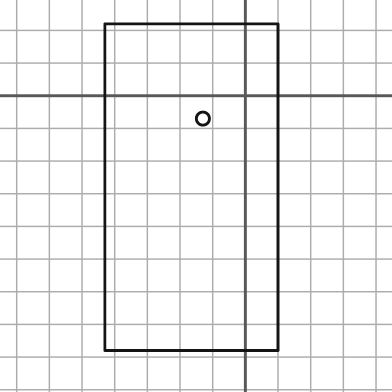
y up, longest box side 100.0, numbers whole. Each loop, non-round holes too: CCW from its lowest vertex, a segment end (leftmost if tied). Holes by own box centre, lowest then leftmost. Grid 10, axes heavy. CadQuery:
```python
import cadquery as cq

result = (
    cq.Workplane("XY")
    .moveTo(-43.0, -78.0)
    .lineTo(10.0, -78.0)
    .lineTo(10.0, 22.0)
    .lineTo(-43.0, 22.0)
    .close()
    .moveTo(-13.0, -7.0)
    .circle(2.0)
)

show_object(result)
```